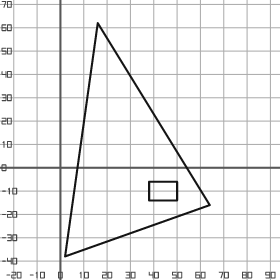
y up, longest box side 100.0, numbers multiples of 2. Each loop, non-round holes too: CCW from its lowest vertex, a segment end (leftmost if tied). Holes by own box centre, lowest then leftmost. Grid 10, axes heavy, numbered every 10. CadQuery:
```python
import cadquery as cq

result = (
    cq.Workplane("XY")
    .moveTo(2.0, -38.0)
    .lineTo(64.0, -16.0)
    .lineTo(16.0, 62.0)
    .close()
    .moveTo(38.0, -14.0)
    .lineTo(50.0, -14.0)
    .lineTo(50.0, -6.0)
    .lineTo(38.0, -6.0)
    .close()
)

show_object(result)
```